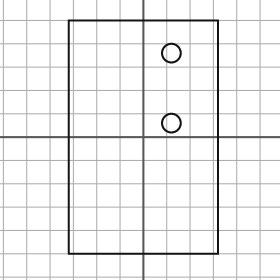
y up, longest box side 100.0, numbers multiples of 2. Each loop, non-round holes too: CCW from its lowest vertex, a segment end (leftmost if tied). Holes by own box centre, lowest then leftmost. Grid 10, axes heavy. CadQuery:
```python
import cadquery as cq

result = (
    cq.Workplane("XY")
    .moveTo(-32.0, -50.0)
    .lineTo(32.0, -50.0)
    .lineTo(32.0, 50.0)
    .lineTo(-32.0, 50.0)
    .close()
    .moveTo(12.0, 6.0)
    .circle(4.0)
    .moveTo(12.0, 36.0)
    .circle(4.0)
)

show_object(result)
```